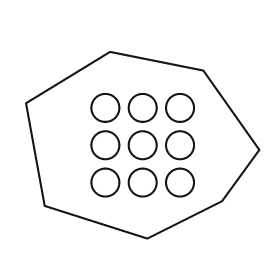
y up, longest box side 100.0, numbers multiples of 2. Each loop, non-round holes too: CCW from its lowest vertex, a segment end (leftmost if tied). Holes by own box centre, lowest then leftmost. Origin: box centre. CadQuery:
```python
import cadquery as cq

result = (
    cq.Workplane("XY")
    .moveTo(2.0, -40.0)
    .lineTo(34.0, -24.0)
    .lineTo(50.0, -2.0)
    .lineTo(26.0, 32.0)
    .lineTo(-14.0, 40.0)
    .lineTo(-50.0, 18.0)
    .lineTo(-42.0, -26.0)
    .close()
    .moveTo(-16.0, -16.0)
    .circle(6.0)
    .moveTo(0.0, -16.0)
    .circle(6.0)
    .moveTo(16.0, -16.0)
    .circle(6.0)
    .moveTo(-16.0, 0.0)
    .circle(6.0)
    .moveTo(0.0, 0.0)
    .circle(6.0)
    .moveTo(16.0, 0.0)
    .circle(6.0)
    .moveTo(-16.0, 16.0)
    .circle(6.0)
    .moveTo(0.0, 16.0)
    .circle(6.0)
    .moveTo(16.0, 16.0)
    .circle(6.0)
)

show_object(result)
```